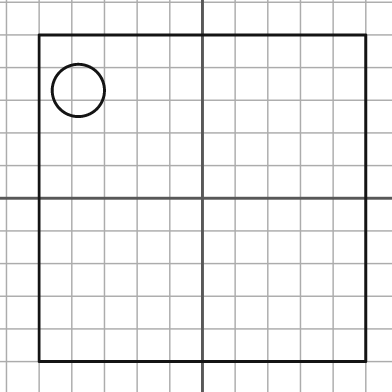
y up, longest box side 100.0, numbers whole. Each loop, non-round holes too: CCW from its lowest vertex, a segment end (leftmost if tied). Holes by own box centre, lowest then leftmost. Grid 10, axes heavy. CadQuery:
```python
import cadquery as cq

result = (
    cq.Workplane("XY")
    .moveTo(-50.0, -50.0)
    .lineTo(50.0, -50.0)
    .lineTo(50.0, 50.0)
    .lineTo(-50.0, 50.0)
    .close()
    .moveTo(-38.0, 33.0)
    .circle(8.0)
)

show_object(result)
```